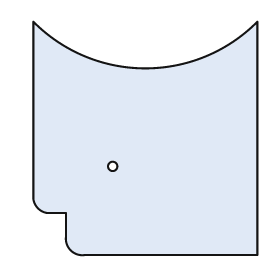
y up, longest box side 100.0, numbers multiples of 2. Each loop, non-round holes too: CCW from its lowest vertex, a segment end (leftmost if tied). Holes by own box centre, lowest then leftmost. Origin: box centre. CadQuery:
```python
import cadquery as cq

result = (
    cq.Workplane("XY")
    .moveTo(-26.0, -50.0)
    .lineTo(48.0, -50.0)
    .lineTo(48.0, 50.0)
    .threePointArc((0.0, 30.0), (-48.0, 50.0))
    .lineTo(-48.0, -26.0)
    .threePointArc((-46.0, -30.0), (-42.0, -32.0))
    .lineTo(-34.0, -32.0)
    .lineTo(-34.0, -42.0)
    .threePointArc((-32.0, -48.0), (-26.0, -50.0))
    .close()
    .moveTo(-14.0, -12.0)
    .circle(2.0)
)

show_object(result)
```